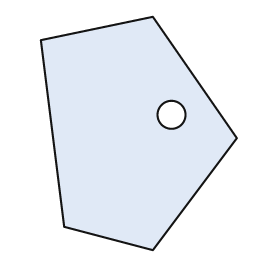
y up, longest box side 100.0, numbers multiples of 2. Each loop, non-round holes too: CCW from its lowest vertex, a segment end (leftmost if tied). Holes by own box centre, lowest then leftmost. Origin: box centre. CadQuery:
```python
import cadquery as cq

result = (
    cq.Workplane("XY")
    .moveTo(6.0, -50.0)
    .lineTo(42.0, -2.0)
    .lineTo(6.0, 50.0)
    .lineTo(-42.0, 40.0)
    .lineTo(-32.0, -40.0)
    .close()
    .moveTo(14.0, 8.0)
    .circle(6.0)
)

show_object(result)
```